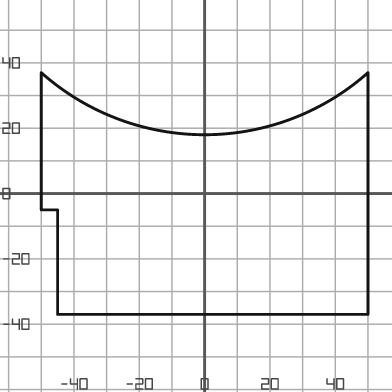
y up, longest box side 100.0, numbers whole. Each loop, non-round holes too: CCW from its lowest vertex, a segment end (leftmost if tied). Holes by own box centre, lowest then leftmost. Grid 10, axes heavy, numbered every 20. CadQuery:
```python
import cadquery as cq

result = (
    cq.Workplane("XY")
    .moveTo(-45.0, -37.0)
    .lineTo(50.0, -37.0)
    .lineTo(50.0, 37.0)
    .threePointArc((0.0, 18.0), (-50.0, 37.0))
    .lineTo(-50.0, -5.0)
    .lineTo(-45.0, -5.0)
    .close()
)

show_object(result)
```